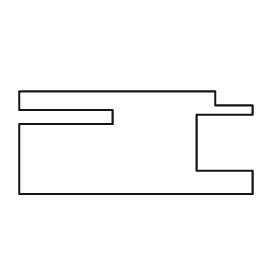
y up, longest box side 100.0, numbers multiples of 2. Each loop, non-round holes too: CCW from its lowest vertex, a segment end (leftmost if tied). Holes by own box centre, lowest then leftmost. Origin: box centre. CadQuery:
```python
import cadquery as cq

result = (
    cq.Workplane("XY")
    .moveTo(-50.0, -22.0)
    .lineTo(50.0, -22.0)
    .lineTo(50.0, -12.0)
    .lineTo(26.0, -12.0)
    .lineTo(26.0, 12.0)
    .lineTo(50.0, 12.0)
    .lineTo(50.0, 16.0)
    .lineTo(34.0, 16.0)
    .lineTo(34.0, 22.0)
    .lineTo(-50.0, 22.0)
    .lineTo(-50.0, 14.0)
    .lineTo(-10.0, 14.0)
    .lineTo(-10.0, 8.0)
    .lineTo(-50.0, 8.0)
    .close()
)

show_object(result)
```